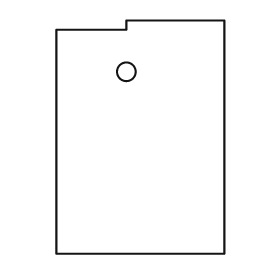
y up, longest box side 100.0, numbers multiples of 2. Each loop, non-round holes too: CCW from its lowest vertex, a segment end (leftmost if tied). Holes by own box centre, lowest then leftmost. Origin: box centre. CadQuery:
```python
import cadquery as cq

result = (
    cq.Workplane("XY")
    .moveTo(-36.0, -50.0)
    .lineTo(36.0, -50.0)
    .lineTo(36.0, 50.0)
    .lineTo(-6.0, 50.0)
    .lineTo(-6.0, 46.0)
    .lineTo(-36.0, 46.0)
    .close()
    .moveTo(-6.0, 28.0)
    .circle(4.0)
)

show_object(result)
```